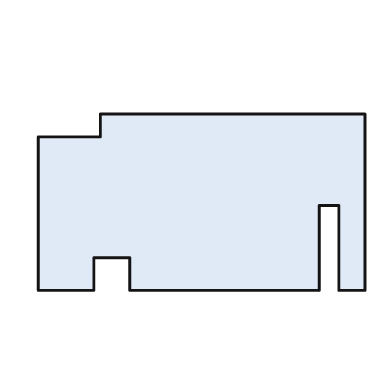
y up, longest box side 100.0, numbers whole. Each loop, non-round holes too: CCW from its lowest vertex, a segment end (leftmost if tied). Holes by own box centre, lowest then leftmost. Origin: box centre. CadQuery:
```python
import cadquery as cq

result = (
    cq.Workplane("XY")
    .moveTo(-50.0, -27.0)
    .lineTo(-33.0, -27.0)
    .lineTo(-33.0, -17.0)
    .lineTo(-22.0, -17.0)
    .lineTo(-22.0, -27.0)
    .lineTo(36.0, -27.0)
    .lineTo(36.0, -1.0)
    .lineTo(42.0, -1.0)
    .lineTo(42.0, -27.0)
    .lineTo(50.0, -27.0)
    .lineTo(50.0, 27.0)
    .lineTo(-31.0, 27.0)
    .lineTo(-31.0, 20.0)
    .lineTo(-50.0, 20.0)
    .close()
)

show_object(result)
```